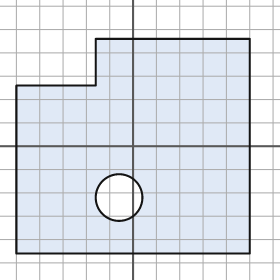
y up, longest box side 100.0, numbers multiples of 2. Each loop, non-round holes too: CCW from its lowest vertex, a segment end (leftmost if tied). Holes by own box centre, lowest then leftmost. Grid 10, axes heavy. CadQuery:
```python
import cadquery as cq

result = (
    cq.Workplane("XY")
    .moveTo(-50.0, -46.0)
    .lineTo(50.0, -46.0)
    .lineTo(50.0, 46.0)
    .lineTo(-16.0, 46.0)
    .lineTo(-16.0, 26.0)
    .lineTo(-50.0, 26.0)
    .close()
    .moveTo(-6.0, -22.0)
    .circle(10.0)
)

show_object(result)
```